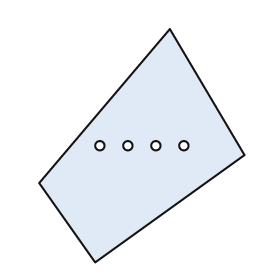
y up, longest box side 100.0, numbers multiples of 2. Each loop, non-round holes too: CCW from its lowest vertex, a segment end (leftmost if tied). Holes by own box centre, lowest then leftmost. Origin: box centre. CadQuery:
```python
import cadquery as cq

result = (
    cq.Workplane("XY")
    .moveTo(-20.0, -50.0)
    .lineTo(44.0, -4.0)
    .lineTo(12.0, 50.0)
    .lineTo(-44.0, -16.0)
    .close()
    .moveTo(-18.0, 0.0)
    .circle(2.0)
    .moveTo(-6.0, 0.0)
    .circle(2.0)
    .moveTo(6.0, 0.0)
    .circle(2.0)
    .moveTo(18.0, 0.0)
    .circle(2.0)
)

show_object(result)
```